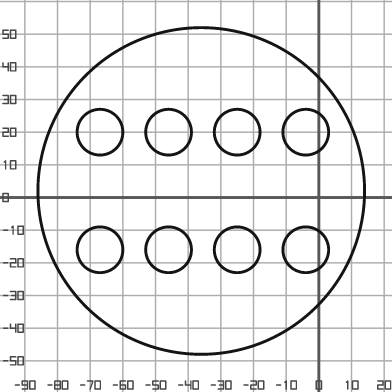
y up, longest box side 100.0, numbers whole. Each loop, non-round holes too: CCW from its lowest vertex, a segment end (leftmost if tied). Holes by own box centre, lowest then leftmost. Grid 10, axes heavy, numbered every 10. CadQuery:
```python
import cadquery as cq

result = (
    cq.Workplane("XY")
    .moveTo(-36.0, 2.0)
    .circle(50.0)
    .moveTo(-67.0, -16.0)
    .circle(7.0)
    .moveTo(-46.0, -16.0)
    .circle(7.0)
    .moveTo(-25.0, -16.0)
    .circle(7.0)
    .moveTo(-4.0, -16.0)
    .circle(7.0)
    .moveTo(-67.0, 20.0)
    .circle(7.0)
    .moveTo(-46.0, 20.0)
    .circle(7.0)
    .moveTo(-25.0, 20.0)
    .circle(7.0)
    .moveTo(-4.0, 20.0)
    .circle(7.0)
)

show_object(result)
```